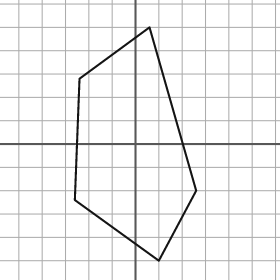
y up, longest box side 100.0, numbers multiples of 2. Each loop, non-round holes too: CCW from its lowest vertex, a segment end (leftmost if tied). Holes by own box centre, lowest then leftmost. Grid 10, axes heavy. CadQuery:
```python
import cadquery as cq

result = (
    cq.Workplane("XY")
    .moveTo(10.0, -50.0)
    .lineTo(26.0, -20.0)
    .lineTo(6.0, 50.0)
    .lineTo(-24.0, 28.0)
    .lineTo(-26.0, -24.0)
    .close()
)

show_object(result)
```